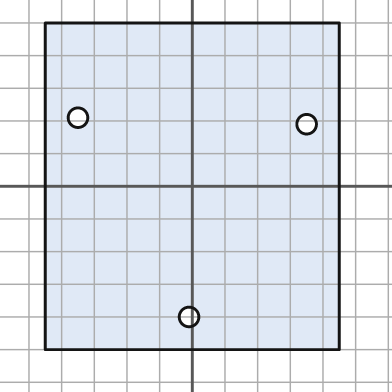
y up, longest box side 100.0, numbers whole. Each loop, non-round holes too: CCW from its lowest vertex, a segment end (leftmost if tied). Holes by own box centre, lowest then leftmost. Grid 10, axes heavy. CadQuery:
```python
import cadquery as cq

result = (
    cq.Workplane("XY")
    .moveTo(-45.0, -50.0)
    .lineTo(45.0, -50.0)
    .lineTo(45.0, 50.0)
    .lineTo(-45.0, 50.0)
    .close()
    .moveTo(-1.0, -40.0)
    .circle(3.0)
    .moveTo(35.0, 19.0)
    .circle(3.0)
    .moveTo(-35.0, 21.0)
    .circle(3.0)
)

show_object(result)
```